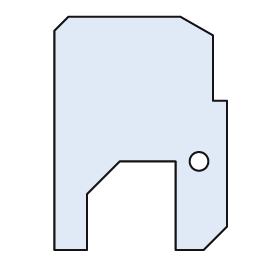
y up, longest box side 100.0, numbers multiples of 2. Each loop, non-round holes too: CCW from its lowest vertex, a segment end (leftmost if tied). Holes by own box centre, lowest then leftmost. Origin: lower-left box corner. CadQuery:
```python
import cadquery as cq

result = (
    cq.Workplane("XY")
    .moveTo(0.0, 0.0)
    .lineTo(14.0, 0.0)
    .lineTo(14.0, 24.0)
    .lineTo(28.0, 38.0)
    .lineTo(52.0, 38.0)
    .lineTo(52.0, 0.0)
    .lineTo(64.0, 0.0)
    .lineTo(74.0, 10.0)
    .lineTo(74.0, 64.0)
    .lineTo(68.0, 64.0)
    .lineTo(68.0, 92.0)
    .lineTo(54.0, 100.0)
    .lineTo(6.0, 100.0)
    .lineTo(0.0, 94.0)
    .close()
    .moveTo(62.0, 38.0)
    .circle(4.0)
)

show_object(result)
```